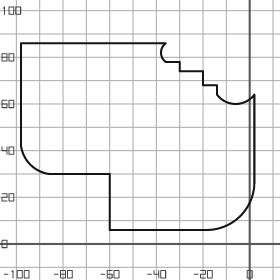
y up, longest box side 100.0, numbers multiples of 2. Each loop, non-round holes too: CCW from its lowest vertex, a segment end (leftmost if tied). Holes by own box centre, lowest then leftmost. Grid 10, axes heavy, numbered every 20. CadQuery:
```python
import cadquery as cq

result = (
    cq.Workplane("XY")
    .moveTo(-60.0, 6.0)
    .lineTo(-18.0, 6.0)
    .threePointArc((-4.0, 12.0), (2.0, 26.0))
    .lineTo(2.0, 64.0)
    .threePointArc((-6.0, 60.0), (-14.0, 64.0))
    .lineTo(-14.0, 68.0)
    .lineTo(-20.0, 68.0)
    .lineTo(-20.0, 74.0)
    .lineTo(-30.0, 74.0)
    .lineTo(-30.0, 78.0)
    .lineTo(-36.0, 78.0)
    .threePointArc((-38.0, 82.0), (-36.0, 86.0))
    .lineTo(-98.0, 86.0)
    .lineTo(-98.0, 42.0)
    .threePointArc((-94.0, 34.0), (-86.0, 30.0))
    .lineTo(-60.0, 30.0)
    .close()
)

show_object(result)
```